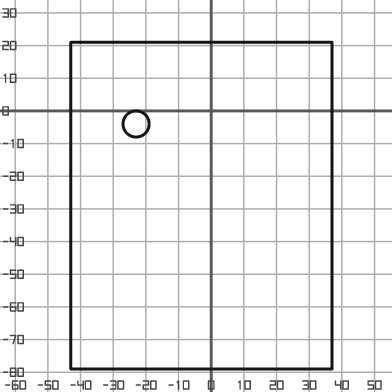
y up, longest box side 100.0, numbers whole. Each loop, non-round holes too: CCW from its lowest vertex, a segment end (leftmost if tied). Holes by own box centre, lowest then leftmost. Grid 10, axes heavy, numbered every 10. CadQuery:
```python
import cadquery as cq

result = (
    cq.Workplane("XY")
    .moveTo(-43.0, -79.0)
    .lineTo(37.0, -79.0)
    .lineTo(37.0, 21.0)
    .lineTo(-43.0, 21.0)
    .close()
    .moveTo(-23.0, -4.0)
    .circle(4.0)
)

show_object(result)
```